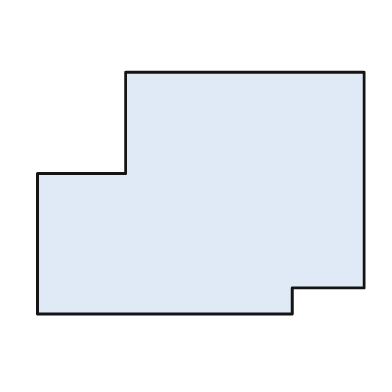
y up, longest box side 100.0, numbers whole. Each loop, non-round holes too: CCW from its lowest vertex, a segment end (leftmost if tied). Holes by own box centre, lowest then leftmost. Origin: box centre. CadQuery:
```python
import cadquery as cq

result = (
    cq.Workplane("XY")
    .moveTo(-50.0, -37.0)
    .lineTo(28.0, -37.0)
    .lineTo(28.0, -29.0)
    .lineTo(50.0, -29.0)
    .lineTo(50.0, 37.0)
    .lineTo(-23.0, 37.0)
    .lineTo(-23.0, 6.0)
    .lineTo(-50.0, 6.0)
    .close()
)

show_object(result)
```